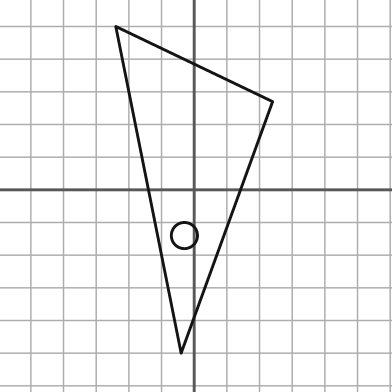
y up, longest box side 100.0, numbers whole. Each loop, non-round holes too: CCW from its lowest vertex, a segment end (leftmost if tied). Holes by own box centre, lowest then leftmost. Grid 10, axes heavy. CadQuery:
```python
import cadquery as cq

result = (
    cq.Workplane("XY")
    .moveTo(-4.0, -50.0)
    .lineTo(24.0, 27.0)
    .lineTo(-24.0, 50.0)
    .close()
    .moveTo(-3.0, -14.0)
    .circle(4.0)
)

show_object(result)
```